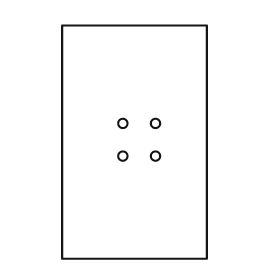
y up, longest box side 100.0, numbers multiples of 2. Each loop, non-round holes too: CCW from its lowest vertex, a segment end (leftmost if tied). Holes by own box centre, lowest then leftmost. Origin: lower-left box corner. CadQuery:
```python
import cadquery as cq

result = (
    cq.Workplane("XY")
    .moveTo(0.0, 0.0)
    .lineTo(62.0, 0.0)
    .lineTo(62.0, 100.0)
    .lineTo(0.0, 100.0)
    .close()
    .moveTo(26.0, 44.0)
    .circle(2.0)
    .moveTo(40.0, 44.0)
    .circle(2.0)
    .moveTo(26.0, 58.0)
    .circle(2.0)
    .moveTo(40.0, 58.0)
    .circle(2.0)
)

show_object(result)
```